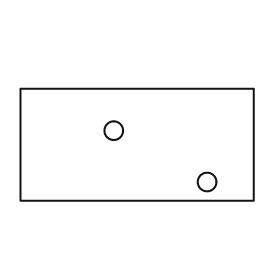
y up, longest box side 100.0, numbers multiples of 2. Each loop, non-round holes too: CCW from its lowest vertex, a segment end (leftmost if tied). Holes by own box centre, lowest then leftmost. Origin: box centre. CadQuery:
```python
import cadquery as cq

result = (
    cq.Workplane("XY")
    .moveTo(-50.0, -24.0)
    .lineTo(50.0, -24.0)
    .lineTo(50.0, 24.0)
    .lineTo(-50.0, 24.0)
    .close()
    .moveTo(30.0, -16.0)
    .circle(4.0)
    .moveTo(-10.0, 6.0)
    .circle(4.0)
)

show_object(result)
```